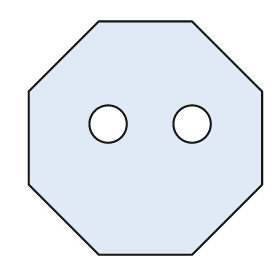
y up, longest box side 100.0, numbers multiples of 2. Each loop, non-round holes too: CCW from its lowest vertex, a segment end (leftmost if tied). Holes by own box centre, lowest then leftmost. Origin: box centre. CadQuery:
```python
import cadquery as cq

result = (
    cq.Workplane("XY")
    .moveTo(-20.0, -50.0)
    .lineTo(20.0, -50.0)
    .lineTo(50.0, -20.0)
    .lineTo(50.0, 20.0)
    .lineTo(20.0, 50.0)
    .lineTo(-20.0, 50.0)
    .lineTo(-50.0, 20.0)
    .lineTo(-50.0, -20.0)
    .close()
    .moveTo(-16.0, 6.0)
    .circle(8.0)
    .moveTo(20.0, 6.0)
    .circle(8.0)
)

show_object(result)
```